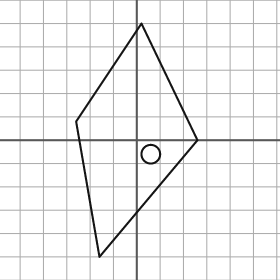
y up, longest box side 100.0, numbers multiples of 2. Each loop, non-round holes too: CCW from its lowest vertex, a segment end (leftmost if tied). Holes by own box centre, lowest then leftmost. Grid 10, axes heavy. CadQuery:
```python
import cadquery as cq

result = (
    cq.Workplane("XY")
    .moveTo(-16.0, -50.0)
    .lineTo(26.0, 0.0)
    .lineTo(2.0, 50.0)
    .lineTo(-26.0, 8.0)
    .close()
    .moveTo(6.0, -6.0)
    .circle(4.0)
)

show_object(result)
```